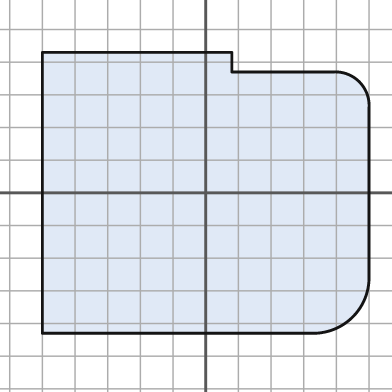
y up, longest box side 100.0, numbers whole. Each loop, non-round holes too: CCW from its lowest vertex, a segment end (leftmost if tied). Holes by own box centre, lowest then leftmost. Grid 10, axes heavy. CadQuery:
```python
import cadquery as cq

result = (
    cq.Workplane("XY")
    .moveTo(-50.0, -43.0)
    .lineTo(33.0, -43.0)
    .threePointArc((45.0, -38.0), (50.0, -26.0))
    .lineTo(50.0, 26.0)
    .threePointArc((47.0, 34.0), (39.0, 37.0))
    .lineTo(8.0, 37.0)
    .lineTo(8.0, 43.0)
    .lineTo(-50.0, 43.0)
    .close()
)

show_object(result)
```